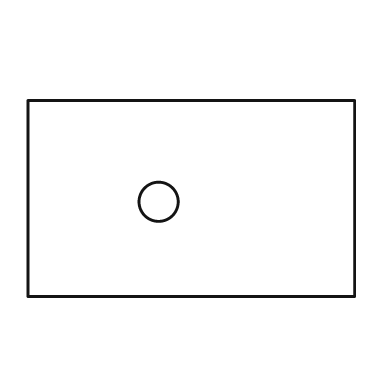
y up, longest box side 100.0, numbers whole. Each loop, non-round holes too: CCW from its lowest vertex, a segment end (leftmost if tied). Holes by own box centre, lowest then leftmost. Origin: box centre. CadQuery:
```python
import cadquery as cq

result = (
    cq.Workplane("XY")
    .moveTo(-50.0, -30.0)
    .lineTo(50.0, -30.0)
    .lineTo(50.0, 30.0)
    .lineTo(-50.0, 30.0)
    .close()
    .moveTo(-10.0, -1.0)
    .circle(6.0)
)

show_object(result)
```